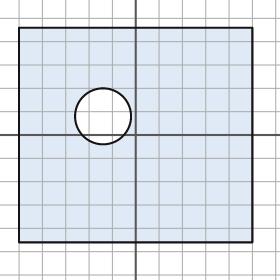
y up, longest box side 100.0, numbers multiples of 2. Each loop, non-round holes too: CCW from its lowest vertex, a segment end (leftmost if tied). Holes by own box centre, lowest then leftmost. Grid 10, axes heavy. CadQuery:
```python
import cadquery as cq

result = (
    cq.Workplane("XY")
    .moveTo(-50.0, -46.0)
    .lineTo(50.0, -46.0)
    .lineTo(50.0, 46.0)
    .lineTo(-50.0, 46.0)
    .close()
    .moveTo(-14.0, 8.0)
    .circle(12.0)
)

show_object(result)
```